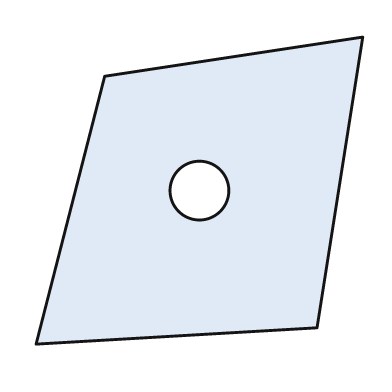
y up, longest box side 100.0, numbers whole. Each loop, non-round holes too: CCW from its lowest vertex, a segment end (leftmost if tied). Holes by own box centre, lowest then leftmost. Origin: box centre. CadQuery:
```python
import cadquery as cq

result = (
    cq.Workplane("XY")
    .moveTo(-50.0, -47.0)
    .lineTo(36.0, -42.0)
    .lineTo(50.0, 47.0)
    .lineTo(-29.0, 35.0)
    .close()
    .moveTo(0.0, 0.0)
    .circle(9.0)
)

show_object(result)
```